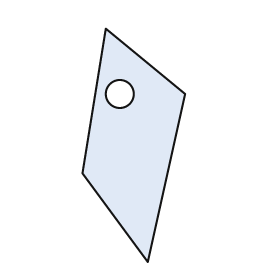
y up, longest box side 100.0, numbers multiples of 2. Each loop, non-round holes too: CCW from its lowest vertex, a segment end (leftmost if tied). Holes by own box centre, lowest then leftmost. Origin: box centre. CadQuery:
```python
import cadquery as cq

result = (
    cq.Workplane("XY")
    .moveTo(6.0, -50.0)
    .lineTo(22.0, 22.0)
    .lineTo(-12.0, 50.0)
    .lineTo(-22.0, -12.0)
    .close()
    .moveTo(-6.0, 22.0)
    .circle(6.0)
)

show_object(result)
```